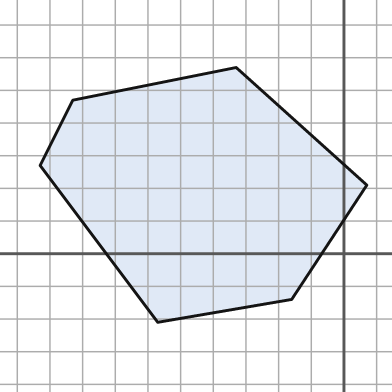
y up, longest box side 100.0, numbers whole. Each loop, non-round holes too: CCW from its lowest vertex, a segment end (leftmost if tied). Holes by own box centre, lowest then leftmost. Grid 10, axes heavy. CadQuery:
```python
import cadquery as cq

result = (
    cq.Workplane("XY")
    .moveTo(-57.0, -21.0)
    .lineTo(-16.0, -14.0)
    .lineTo(7.0, 21.0)
    .lineTo(-33.0, 57.0)
    .lineTo(-83.0, 47.0)
    .lineTo(-93.0, 27.0)
    .close()
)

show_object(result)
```